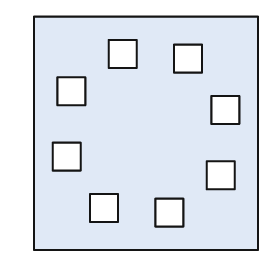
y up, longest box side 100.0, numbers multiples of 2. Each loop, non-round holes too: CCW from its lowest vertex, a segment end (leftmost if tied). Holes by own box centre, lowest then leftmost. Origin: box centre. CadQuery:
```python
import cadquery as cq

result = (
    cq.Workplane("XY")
    .moveTo(-48.0, -50.0)
    .lineTo(48.0, -50.0)
    .lineTo(48.0, 50.0)
    .lineTo(-48.0, 50.0)
    .close()
    .moveTo(4.0, -40.0)
    .lineTo(16.0, -40.0)
    .lineTo(16.0, -28.0)
    .lineTo(4.0, -28.0)
    .close()
    .moveTo(-24.0, -38.0)
    .lineTo(-12.0, -38.0)
    .lineTo(-12.0, -26.0)
    .lineTo(-24.0, -26.0)
    .close()
    .moveTo(26.0, -24.0)
    .lineTo(38.0, -24.0)
    .lineTo(38.0, -12.0)
    .lineTo(26.0, -12.0)
    .close()
    .moveTo(-40.0, -16.0)
    .lineTo(-28.0, -16.0)
    .lineTo(-28.0, -4.0)
    .lineTo(-40.0, -4.0)
    .close()
    .moveTo(28.0, 4.0)
    .lineTo(40.0, 4.0)
    .lineTo(40.0, 16.0)
    .lineTo(28.0, 16.0)
    .close()
    .moveTo(-38.0, 12.0)
    .lineTo(-26.0, 12.0)
    .lineTo(-26.0, 24.0)
    .lineTo(-38.0, 24.0)
    .close()
    .moveTo(12.0, 26.0)
    .lineTo(24.0, 26.0)
    .lineTo(24.0, 38.0)
    .lineTo(12.0, 38.0)
    .close()
    .moveTo(-16.0, 28.0)
    .lineTo(-4.0, 28.0)
    .lineTo(-4.0, 40.0)
    .lineTo(-16.0, 40.0)
    .close()
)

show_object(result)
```